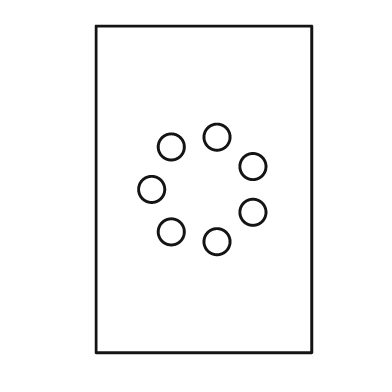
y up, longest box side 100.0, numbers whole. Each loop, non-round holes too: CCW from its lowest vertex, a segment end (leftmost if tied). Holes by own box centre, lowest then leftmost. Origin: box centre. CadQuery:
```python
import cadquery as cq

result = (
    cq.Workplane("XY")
    .moveTo(-33.0, -50.0)
    .lineTo(33.0, -50.0)
    .lineTo(33.0, 50.0)
    .lineTo(-33.0, 50.0)
    .close()
    .moveTo(4.0, -16.0)
    .circle(4.0)
    .moveTo(-10.0, -13.0)
    .circle(4.0)
    .moveTo(15.0, -7.0)
    .circle(4.0)
    .moveTo(-16.0, 0.0)
    .circle(4.0)
    .moveTo(15.0, 7.0)
    .circle(4.0)
    .moveTo(-10.0, 13.0)
    .circle(4.0)
    .moveTo(4.0, 16.0)
    .circle(4.0)
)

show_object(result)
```